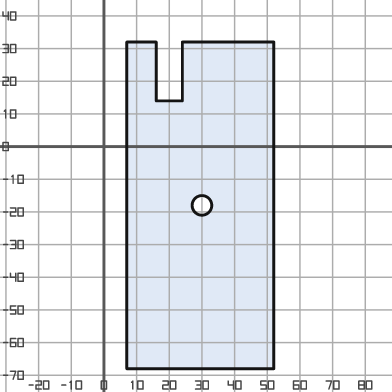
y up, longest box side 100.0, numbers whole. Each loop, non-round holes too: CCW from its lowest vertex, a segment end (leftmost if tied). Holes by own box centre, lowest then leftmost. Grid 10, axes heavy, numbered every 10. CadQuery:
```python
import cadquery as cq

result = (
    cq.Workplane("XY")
    .moveTo(7.0, -68.0)
    .lineTo(52.0, -68.0)
    .lineTo(52.0, 32.0)
    .lineTo(24.0, 32.0)
    .lineTo(24.0, 14.0)
    .lineTo(16.0, 14.0)
    .lineTo(16.0, 32.0)
    .lineTo(7.0, 32.0)
    .close()
    .moveTo(30.0, -18.0)
    .circle(3.0)
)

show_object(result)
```